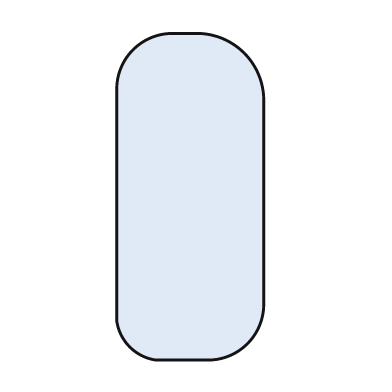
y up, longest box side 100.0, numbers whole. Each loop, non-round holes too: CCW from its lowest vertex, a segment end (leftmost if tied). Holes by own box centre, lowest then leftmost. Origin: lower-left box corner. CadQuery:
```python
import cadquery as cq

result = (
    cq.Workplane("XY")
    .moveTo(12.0, 0.0)
    .lineTo(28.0, 0.0)
    .threePointArc((40.0, 5.0), (45.0, 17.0))
    .lineTo(45.0, 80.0)
    .threePointArc((39.0, 94.0), (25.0, 100.0))
    .lineTo(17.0, 100.0)
    .threePointArc((5.0, 95.0), (0.0, 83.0))
    .lineTo(0.0, 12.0)
    .threePointArc((4.0, 4.0), (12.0, 0.0))
    .close()
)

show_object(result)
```